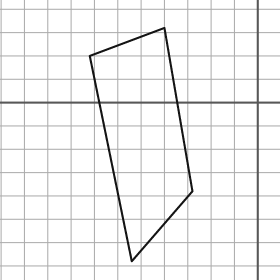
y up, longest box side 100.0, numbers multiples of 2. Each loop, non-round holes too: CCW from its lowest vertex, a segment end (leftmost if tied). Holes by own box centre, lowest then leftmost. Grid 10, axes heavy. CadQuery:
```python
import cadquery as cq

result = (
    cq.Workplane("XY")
    .moveTo(-54.0, -68.0)
    .lineTo(-28.0, -38.0)
    .lineTo(-40.0, 32.0)
    .lineTo(-72.0, 20.0)
    .close()
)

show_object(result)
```